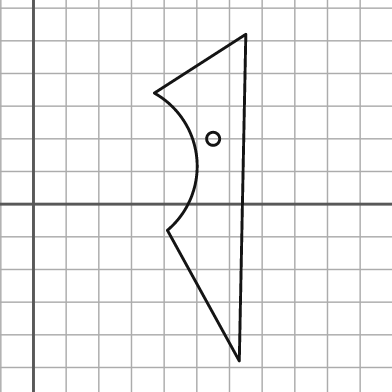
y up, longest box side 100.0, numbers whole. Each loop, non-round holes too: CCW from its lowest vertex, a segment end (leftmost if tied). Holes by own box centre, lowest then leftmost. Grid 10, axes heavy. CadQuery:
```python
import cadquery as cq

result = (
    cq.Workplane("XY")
    .moveTo(63.0, -48.0)
    .lineTo(65.0, 52.0)
    .lineTo(37.0, 34.0)
    .threePointArc((50.0, 14.0), (41.0, -8.0))
    .close()
    .moveTo(55.0, 20.0)
    .circle(2.0)
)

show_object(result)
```